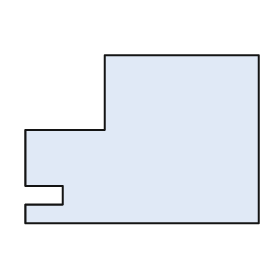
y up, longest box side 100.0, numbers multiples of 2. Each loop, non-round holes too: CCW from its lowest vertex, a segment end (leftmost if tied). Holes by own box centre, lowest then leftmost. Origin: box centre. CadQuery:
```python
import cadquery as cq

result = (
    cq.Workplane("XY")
    .moveTo(-50.0, -36.0)
    .lineTo(50.0, -36.0)
    .lineTo(50.0, 36.0)
    .lineTo(-16.0, 36.0)
    .lineTo(-16.0, 4.0)
    .lineTo(-50.0, 4.0)
    .lineTo(-50.0, -20.0)
    .lineTo(-34.0, -20.0)
    .lineTo(-34.0, -28.0)
    .lineTo(-50.0, -28.0)
    .close()
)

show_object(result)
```